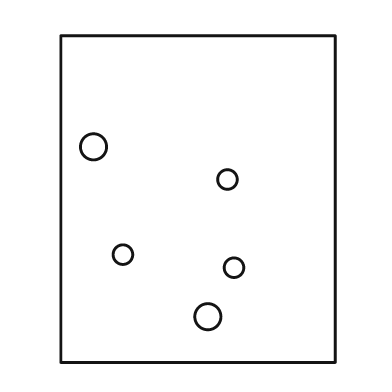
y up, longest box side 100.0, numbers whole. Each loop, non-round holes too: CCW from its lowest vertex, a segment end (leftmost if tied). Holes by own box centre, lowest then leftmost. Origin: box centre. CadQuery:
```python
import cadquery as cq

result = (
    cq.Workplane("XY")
    .moveTo(-42.0, -50.0)
    .lineTo(42.0, -50.0)
    .lineTo(42.0, 50.0)
    .lineTo(-42.0, 50.0)
    .close()
    .moveTo(3.0, -36.0)
    .circle(4.0)
    .moveTo(11.0, -21.0)
    .circle(3.0)
    .moveTo(-23.0, -17.0)
    .circle(3.0)
    .moveTo(9.0, 6.0)
    .circle(3.0)
    .moveTo(-32.0, 16.0)
    .circle(4.0)
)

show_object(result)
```